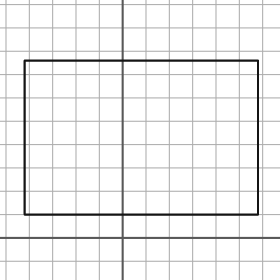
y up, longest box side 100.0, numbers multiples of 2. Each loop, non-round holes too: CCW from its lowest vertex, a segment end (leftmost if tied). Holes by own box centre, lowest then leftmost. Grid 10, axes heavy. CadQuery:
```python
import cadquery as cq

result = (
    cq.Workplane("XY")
    .moveTo(-42.0, 10.0)
    .lineTo(58.0, 10.0)
    .lineTo(58.0, 76.0)
    .lineTo(-42.0, 76.0)
    .close()
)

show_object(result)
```